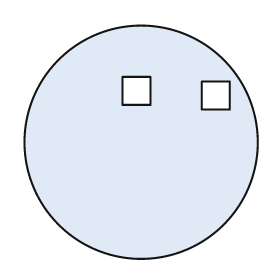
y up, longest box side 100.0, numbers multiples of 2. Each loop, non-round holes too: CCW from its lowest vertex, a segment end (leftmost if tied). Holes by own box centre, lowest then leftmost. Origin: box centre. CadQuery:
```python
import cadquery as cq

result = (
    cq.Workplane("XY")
    .moveTo(0.0, 0.0)
    .circle(50.0)
    .moveTo(26.0, 14.0)
    .lineTo(38.0, 14.0)
    .lineTo(38.0, 26.0)
    .lineTo(26.0, 26.0)
    .close()
    .moveTo(-8.0, 16.0)
    .lineTo(4.0, 16.0)
    .lineTo(4.0, 28.0)
    .lineTo(-8.0, 28.0)
    .close()
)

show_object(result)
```